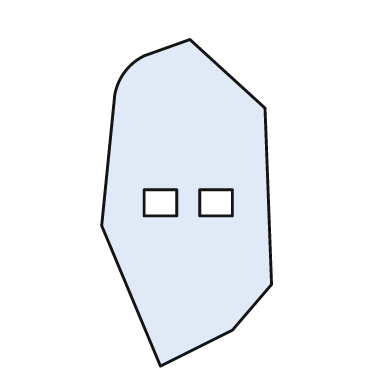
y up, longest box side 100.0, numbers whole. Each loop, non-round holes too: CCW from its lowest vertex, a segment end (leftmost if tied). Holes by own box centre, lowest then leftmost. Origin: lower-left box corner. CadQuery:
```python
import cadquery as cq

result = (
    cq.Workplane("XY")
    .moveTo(18.0, 0.0)
    .lineTo(40.0, 11.0)
    .lineTo(52.0, 25.0)
    .lineTo(50.0, 79.0)
    .lineTo(27.0, 100.0)
    .lineTo(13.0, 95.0)
    .threePointArc((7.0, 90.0), (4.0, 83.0))
    .lineTo(0.0, 43.0)
    .close()
    .moveTo(13.0, 46.0)
    .lineTo(23.0, 46.0)
    .lineTo(23.0, 54.0)
    .lineTo(13.0, 54.0)
    .close()
    .moveTo(30.0, 46.0)
    .lineTo(40.0, 46.0)
    .lineTo(40.0, 54.0)
    .lineTo(30.0, 54.0)
    .close()
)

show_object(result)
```